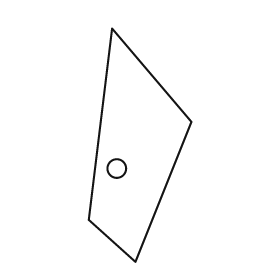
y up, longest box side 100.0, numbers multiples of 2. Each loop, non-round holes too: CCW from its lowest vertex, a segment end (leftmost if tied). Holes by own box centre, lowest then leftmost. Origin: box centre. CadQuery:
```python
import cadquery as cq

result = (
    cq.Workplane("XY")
    .moveTo(-2.0, -50.0)
    .lineTo(22.0, 10.0)
    .lineTo(-12.0, 50.0)
    .lineTo(-22.0, -32.0)
    .close()
    .moveTo(-10.0, -10.0)
    .circle(4.0)
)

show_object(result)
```